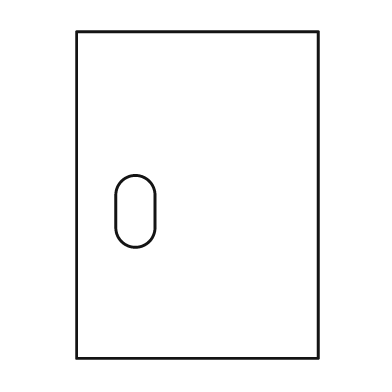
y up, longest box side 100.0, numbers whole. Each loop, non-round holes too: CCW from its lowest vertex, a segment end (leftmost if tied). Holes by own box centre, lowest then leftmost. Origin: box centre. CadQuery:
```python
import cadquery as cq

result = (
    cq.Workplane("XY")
    .moveTo(-37.0, -50.0)
    .lineTo(37.0, -50.0)
    .lineTo(37.0, 50.0)
    .lineTo(-37.0, 50.0)
    .close()
    .moveTo(-25.0, -10.0)
    .threePointArc((-19.0, -16.0), (-13.0, -10.0))
    .lineTo(-13.0, 0.0)
    .threePointArc((-19.0, 6.0), (-25.0, 0.0))
    .close()
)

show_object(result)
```